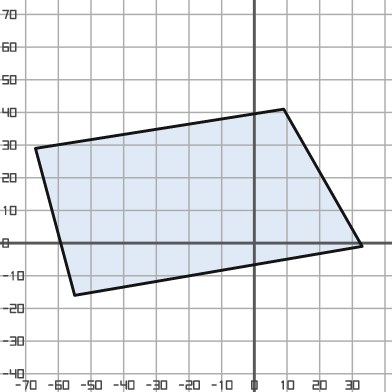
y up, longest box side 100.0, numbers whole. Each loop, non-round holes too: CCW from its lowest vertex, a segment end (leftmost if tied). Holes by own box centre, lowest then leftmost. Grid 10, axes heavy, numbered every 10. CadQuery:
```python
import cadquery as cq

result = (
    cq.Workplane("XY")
    .moveTo(-55.0, -16.0)
    .lineTo(33.0, -1.0)
    .lineTo(9.0, 41.0)
    .lineTo(-67.0, 29.0)
    .close()
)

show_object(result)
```